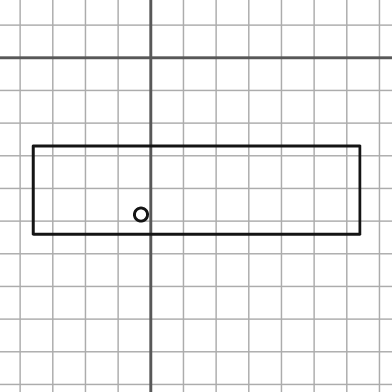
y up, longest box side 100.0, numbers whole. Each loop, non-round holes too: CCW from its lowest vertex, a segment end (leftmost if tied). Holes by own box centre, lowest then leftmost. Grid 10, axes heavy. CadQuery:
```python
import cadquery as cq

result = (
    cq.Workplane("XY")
    .moveTo(-36.0, -54.0)
    .lineTo(64.0, -54.0)
    .lineTo(64.0, -27.0)
    .lineTo(-36.0, -27.0)
    .close()
    .moveTo(-3.0, -48.0)
    .circle(2.0)
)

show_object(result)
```